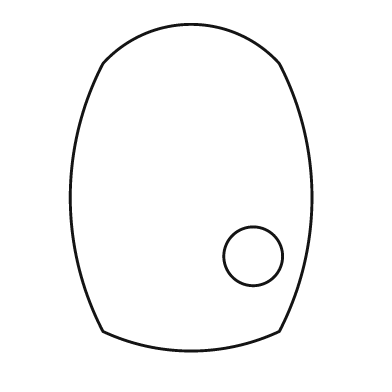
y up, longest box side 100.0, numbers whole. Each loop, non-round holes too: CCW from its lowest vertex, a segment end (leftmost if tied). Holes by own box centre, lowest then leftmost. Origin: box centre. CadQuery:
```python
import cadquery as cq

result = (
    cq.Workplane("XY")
    .moveTo(-27.0, -44.0)
    .threePointArc((0.0, -50.0), (27.0, -44.0))
    .threePointArc((37.0, -3.0), (27.0, 38.0))
    .threePointArc((0.0, 50.0), (-27.0, 38.0))
    .threePointArc((-37.0, -3.0), (-27.0, -44.0))
    .close()
    .moveTo(19.0, -21.0)
    .circle(9.0)
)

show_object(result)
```